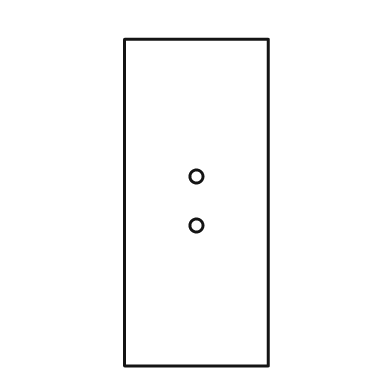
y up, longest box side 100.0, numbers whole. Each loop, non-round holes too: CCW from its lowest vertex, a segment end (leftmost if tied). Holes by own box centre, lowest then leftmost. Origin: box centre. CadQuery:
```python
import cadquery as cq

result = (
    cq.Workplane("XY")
    .moveTo(-22.0, -50.0)
    .lineTo(22.0, -50.0)
    .lineTo(22.0, 50.0)
    .lineTo(-22.0, 50.0)
    .close()
    .moveTo(0.0, -7.0)
    .circle(2.0)
    .moveTo(0.0, 8.0)
    .circle(2.0)
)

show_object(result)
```